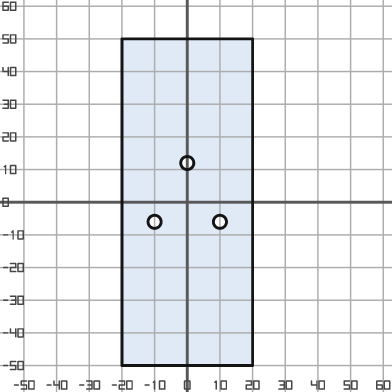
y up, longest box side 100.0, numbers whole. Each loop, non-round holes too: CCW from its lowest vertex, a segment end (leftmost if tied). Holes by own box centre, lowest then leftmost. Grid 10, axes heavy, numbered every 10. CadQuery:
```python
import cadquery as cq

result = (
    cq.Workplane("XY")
    .moveTo(-20.0, -50.0)
    .lineTo(20.0, -50.0)
    .lineTo(20.0, 50.0)
    .lineTo(-20.0, 50.0)
    .close()
    .moveTo(-10.0, -6.0)
    .circle(2.0)
    .moveTo(10.0, -6.0)
    .circle(2.0)
    .moveTo(0.0, 12.0)
    .circle(2.0)
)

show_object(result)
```